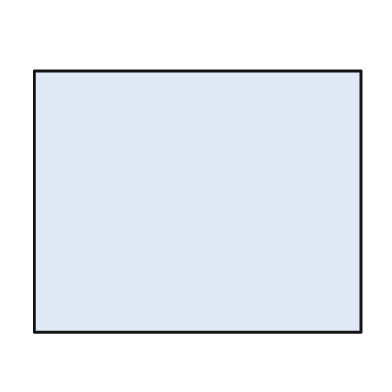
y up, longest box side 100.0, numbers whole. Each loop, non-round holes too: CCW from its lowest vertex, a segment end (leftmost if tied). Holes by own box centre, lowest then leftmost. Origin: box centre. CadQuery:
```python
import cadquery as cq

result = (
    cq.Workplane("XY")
    .moveTo(-50.0, -40.0)
    .lineTo(50.0, -40.0)
    .lineTo(50.0, 40.0)
    .lineTo(-50.0, 40.0)
    .close()
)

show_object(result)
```